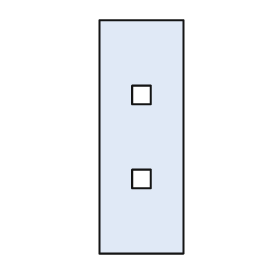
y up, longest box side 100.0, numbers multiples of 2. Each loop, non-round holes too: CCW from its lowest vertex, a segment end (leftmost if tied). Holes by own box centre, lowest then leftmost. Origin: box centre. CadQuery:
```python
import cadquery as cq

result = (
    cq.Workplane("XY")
    .moveTo(-18.0, -50.0)
    .lineTo(18.0, -50.0)
    .lineTo(18.0, 50.0)
    .lineTo(-18.0, 50.0)
    .close()
    .moveTo(-4.0, -22.0)
    .lineTo(4.0, -22.0)
    .lineTo(4.0, -14.0)
    .lineTo(-4.0, -14.0)
    .close()
    .moveTo(-4.0, 14.0)
    .lineTo(4.0, 14.0)
    .lineTo(4.0, 22.0)
    .lineTo(-4.0, 22.0)
    .close()
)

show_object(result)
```